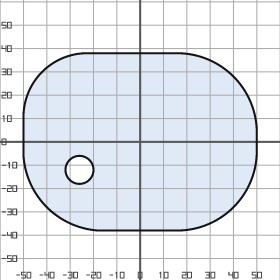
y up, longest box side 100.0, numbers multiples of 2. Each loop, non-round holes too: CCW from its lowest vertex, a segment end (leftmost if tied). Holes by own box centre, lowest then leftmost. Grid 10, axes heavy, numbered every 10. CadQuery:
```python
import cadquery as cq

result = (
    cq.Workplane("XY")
    .moveTo(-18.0, -38.0)
    .lineTo(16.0, -38.0)
    .threePointArc((40.0, -28.0), (50.0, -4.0))
    .lineTo(50.0, 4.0)
    .threePointArc((40.0, 28.0), (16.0, 38.0))
    .lineTo(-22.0, 38.0)
    .threePointArc((-42.0, 30.0), (-50.0, 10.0))
    .lineTo(-50.0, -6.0)
    .threePointArc((-40.0, -28.0), (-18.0, -38.0))
    .close()
    .moveTo(-26.0, -12.0)
    .circle(6.0)
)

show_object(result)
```